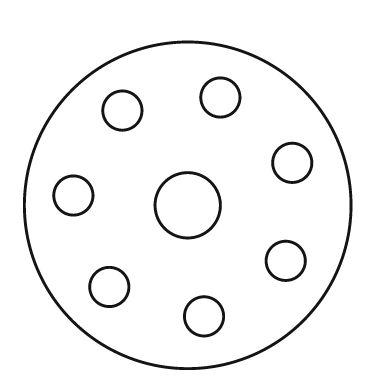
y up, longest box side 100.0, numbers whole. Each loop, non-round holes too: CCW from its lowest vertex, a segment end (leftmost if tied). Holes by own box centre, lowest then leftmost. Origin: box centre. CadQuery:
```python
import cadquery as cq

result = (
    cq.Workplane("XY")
    .moveTo(0.0, 0.0)
    .circle(50.0)
    .moveTo(5.0, -34.0)
    .circle(6.0)
    .moveTo(-24.0, -25.0)
    .circle(6.0)
    .moveTo(30.0, -17.0)
    .circle(6.0)
    .moveTo(0.0, 0.0)
    .circle(10.0)
    .moveTo(-35.0, 3.0)
    .circle(6.0)
    .moveTo(32.0, 13.0)
    .circle(6.0)
    .moveTo(-20.0, 29.0)
    .circle(6.0)
    .moveTo(10.0, 33.0)
    .circle(6.0)
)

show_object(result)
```